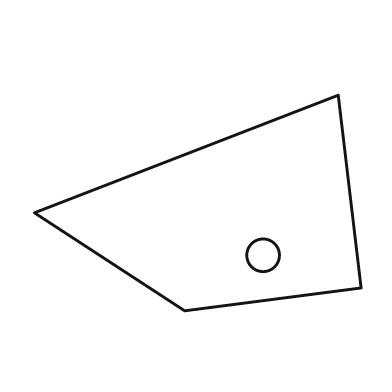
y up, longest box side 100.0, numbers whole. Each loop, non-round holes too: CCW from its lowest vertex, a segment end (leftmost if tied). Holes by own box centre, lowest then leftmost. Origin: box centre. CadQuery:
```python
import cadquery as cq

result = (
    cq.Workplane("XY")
    .moveTo(-4.0, -33.0)
    .lineTo(50.0, -26.0)
    .lineTo(43.0, 33.0)
    .lineTo(-50.0, -3.0)
    .close()
    .moveTo(20.0, -16.0)
    .circle(5.0)
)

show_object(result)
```